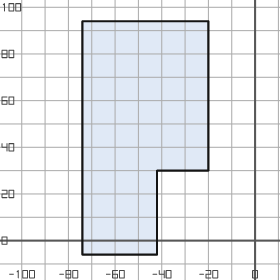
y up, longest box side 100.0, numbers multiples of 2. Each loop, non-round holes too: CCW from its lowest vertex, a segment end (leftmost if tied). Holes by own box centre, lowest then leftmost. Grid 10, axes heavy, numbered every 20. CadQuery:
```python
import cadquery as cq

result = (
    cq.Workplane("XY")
    .moveTo(-74.0, -6.0)
    .lineTo(-42.0, -6.0)
    .lineTo(-42.0, 30.0)
    .lineTo(-20.0, 30.0)
    .lineTo(-20.0, 94.0)
    .lineTo(-74.0, 94.0)
    .close()
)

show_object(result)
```